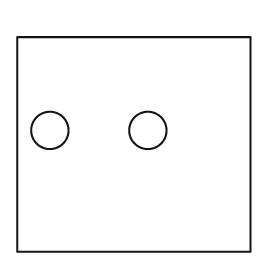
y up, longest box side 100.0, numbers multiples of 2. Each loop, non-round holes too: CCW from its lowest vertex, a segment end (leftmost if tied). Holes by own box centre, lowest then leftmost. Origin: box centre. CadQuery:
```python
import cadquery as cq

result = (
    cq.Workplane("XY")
    .moveTo(-50.0, -46.0)
    .lineTo(50.0, -46.0)
    .lineTo(50.0, 46.0)
    .lineTo(-50.0, 46.0)
    .close()
    .moveTo(-36.0, 6.0)
    .circle(8.0)
    .moveTo(6.0, 6.0)
    .circle(8.0)
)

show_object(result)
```